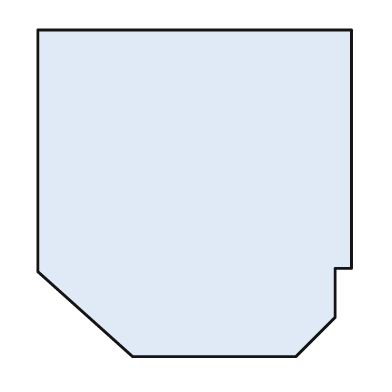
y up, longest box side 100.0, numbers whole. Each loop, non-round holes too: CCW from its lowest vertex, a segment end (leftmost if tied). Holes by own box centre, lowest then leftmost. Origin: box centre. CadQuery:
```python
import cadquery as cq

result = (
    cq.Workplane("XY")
    .moveTo(-19.0, -50.0)
    .lineTo(31.0, -50.0)
    .lineTo(43.0, -38.0)
    .lineTo(43.0, -23.0)
    .lineTo(48.0, -23.0)
    .lineTo(48.0, 50.0)
    .lineTo(-48.0, 50.0)
    .lineTo(-48.0, -24.0)
    .close()
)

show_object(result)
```